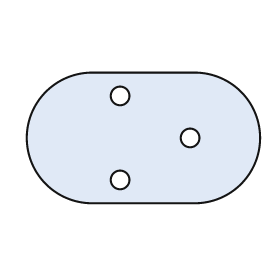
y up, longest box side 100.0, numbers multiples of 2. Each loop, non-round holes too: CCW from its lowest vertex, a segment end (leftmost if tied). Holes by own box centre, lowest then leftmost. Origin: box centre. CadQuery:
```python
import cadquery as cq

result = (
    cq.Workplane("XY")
    .moveTo(-22.0, -28.0)
    .lineTo(22.0, -28.0)
    .threePointArc((50.0, 0.0), (22.0, 28.0))
    .lineTo(-22.0, 28.0)
    .threePointArc((-50.0, 0.0), (-22.0, -28.0))
    .close()
    .moveTo(-10.0, -18.0)
    .circle(4.0)
    .moveTo(20.0, 0.0)
    .circle(4.0)
    .moveTo(-10.0, 18.0)
    .circle(4.0)
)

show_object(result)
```